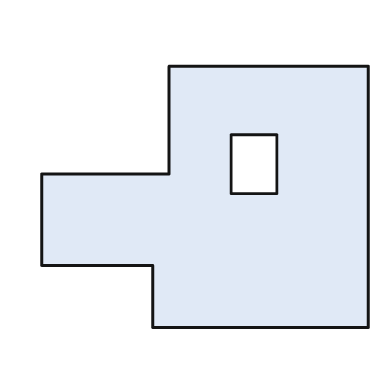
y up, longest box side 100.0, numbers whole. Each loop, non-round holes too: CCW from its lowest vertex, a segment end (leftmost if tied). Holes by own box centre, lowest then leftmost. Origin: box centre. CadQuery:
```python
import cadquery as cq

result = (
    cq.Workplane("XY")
    .moveTo(-16.0, -40.0)
    .lineTo(50.0, -40.0)
    .lineTo(50.0, 40.0)
    .lineTo(-11.0, 40.0)
    .lineTo(-11.0, 7.0)
    .lineTo(-50.0, 7.0)
    .lineTo(-50.0, -21.0)
    .lineTo(-16.0, -21.0)
    .close()
    .moveTo(8.0, 1.0)
    .lineTo(22.0, 1.0)
    .lineTo(22.0, 19.0)
    .lineTo(8.0, 19.0)
    .close()
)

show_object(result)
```